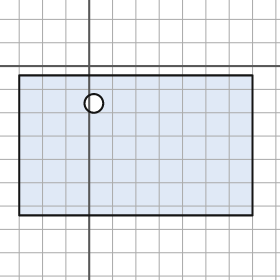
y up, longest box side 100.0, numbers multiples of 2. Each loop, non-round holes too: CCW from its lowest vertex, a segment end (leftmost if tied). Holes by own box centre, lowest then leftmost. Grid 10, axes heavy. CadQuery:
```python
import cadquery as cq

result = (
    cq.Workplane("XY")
    .moveTo(-30.0, -64.0)
    .lineTo(70.0, -64.0)
    .lineTo(70.0, -4.0)
    .lineTo(-30.0, -4.0)
    .close()
    .moveTo(2.0, -16.0)
    .circle(4.0)
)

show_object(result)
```